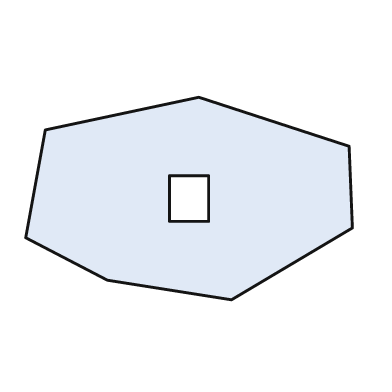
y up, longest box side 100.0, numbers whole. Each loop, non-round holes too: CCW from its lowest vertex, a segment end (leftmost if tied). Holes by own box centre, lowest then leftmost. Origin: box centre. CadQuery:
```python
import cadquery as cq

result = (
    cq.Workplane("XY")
    .moveTo(13.0, -31.0)
    .lineTo(50.0, -9.0)
    .lineTo(49.0, 16.0)
    .lineTo(3.0, 31.0)
    .lineTo(-44.0, 21.0)
    .lineTo(-50.0, -12.0)
    .lineTo(-25.0, -25.0)
    .close()
    .moveTo(-6.0, -7.0)
    .lineTo(6.0, -7.0)
    .lineTo(6.0, 7.0)
    .lineTo(-6.0, 7.0)
    .close()
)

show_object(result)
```